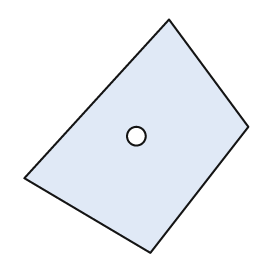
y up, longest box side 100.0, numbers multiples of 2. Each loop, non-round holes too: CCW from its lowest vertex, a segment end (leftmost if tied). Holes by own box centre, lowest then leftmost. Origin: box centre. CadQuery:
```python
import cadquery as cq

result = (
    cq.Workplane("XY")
    .moveTo(6.0, -50.0)
    .lineTo(48.0, 4.0)
    .lineTo(14.0, 50.0)
    .lineTo(-48.0, -18.0)
    .close()
    .moveTo(0.0, 0.0)
    .circle(4.0)
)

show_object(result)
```